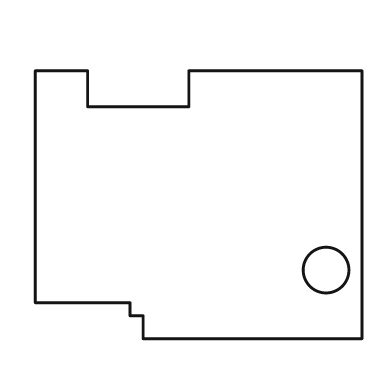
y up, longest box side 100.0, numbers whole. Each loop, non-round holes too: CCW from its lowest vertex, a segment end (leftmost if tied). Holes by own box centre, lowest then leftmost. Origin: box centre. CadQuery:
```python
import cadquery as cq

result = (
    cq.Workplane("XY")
    .moveTo(-17.0, -41.0)
    .lineTo(50.0, -41.0)
    .lineTo(50.0, 41.0)
    .lineTo(-3.0, 41.0)
    .lineTo(-3.0, 30.0)
    .lineTo(-34.0, 30.0)
    .lineTo(-34.0, 41.0)
    .lineTo(-50.0, 41.0)
    .lineTo(-50.0, -30.0)
    .lineTo(-21.0, -30.0)
    .lineTo(-21.0, -34.0)
    .lineTo(-17.0, -34.0)
    .close()
    .moveTo(39.0, -20.0)
    .circle(7.0)
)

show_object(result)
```